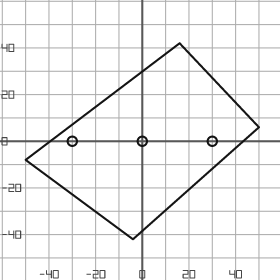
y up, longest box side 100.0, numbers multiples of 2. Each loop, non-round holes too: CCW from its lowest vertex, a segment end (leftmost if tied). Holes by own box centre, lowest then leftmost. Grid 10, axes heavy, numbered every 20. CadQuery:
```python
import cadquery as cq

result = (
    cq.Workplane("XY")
    .moveTo(-4.0, -42.0)
    .lineTo(50.0, 6.0)
    .lineTo(16.0, 42.0)
    .lineTo(-50.0, -8.0)
    .close()
    .moveTo(-30.0, 0.0)
    .circle(2.0)
    .moveTo(0.0, 0.0)
    .circle(2.0)
    .moveTo(30.0, 0.0)
    .circle(2.0)
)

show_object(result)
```